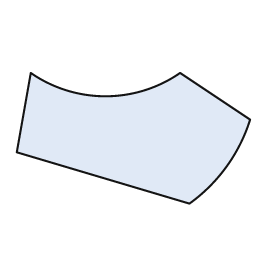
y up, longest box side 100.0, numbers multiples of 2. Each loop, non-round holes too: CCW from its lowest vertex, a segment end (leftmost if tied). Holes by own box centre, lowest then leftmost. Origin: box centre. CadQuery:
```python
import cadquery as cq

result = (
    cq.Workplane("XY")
    .moveTo(24.0, -28.0)
    .threePointArc((40.0, -12.0), (50.0, 8.0))
    .lineTo(20.0, 28.0)
    .threePointArc((-12.0, 18.0), (-44.0, 28.0))
    .lineTo(-50.0, -6.0)
    .close()
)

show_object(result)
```